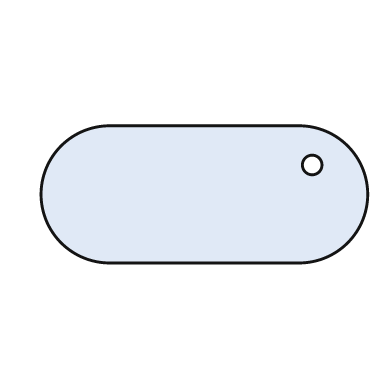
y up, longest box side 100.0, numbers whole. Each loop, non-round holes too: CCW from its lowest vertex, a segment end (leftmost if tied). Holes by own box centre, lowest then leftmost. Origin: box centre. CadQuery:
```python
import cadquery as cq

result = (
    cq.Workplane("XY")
    .moveTo(-29.0, -21.0)
    .lineTo(29.0, -21.0)
    .threePointArc((50.0, 0.0), (29.0, 21.0))
    .lineTo(-29.0, 21.0)
    .threePointArc((-50.0, 0.0), (-29.0, -21.0))
    .close()
    .moveTo(33.0, 9.0)
    .circle(3.0)
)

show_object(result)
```